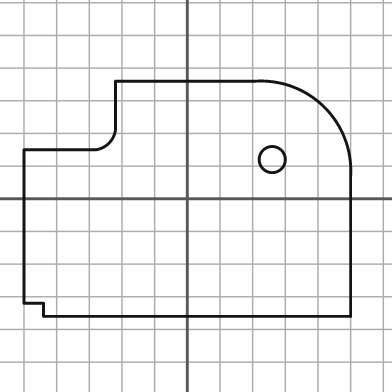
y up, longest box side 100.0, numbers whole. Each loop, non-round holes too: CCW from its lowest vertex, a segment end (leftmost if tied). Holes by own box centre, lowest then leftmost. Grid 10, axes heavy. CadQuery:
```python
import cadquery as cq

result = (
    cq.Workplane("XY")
    .moveTo(-44.0, -36.0)
    .lineTo(50.0, -36.0)
    .lineTo(50.0, 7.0)
    .threePointArc((42.0, 28.0), (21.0, 36.0))
    .lineTo(-22.0, 36.0)
    .lineTo(-22.0, 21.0)
    .threePointArc((-24.0, 17.0), (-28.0, 15.0))
    .lineTo(-50.0, 15.0)
    .lineTo(-50.0, -32.0)
    .lineTo(-44.0, -32.0)
    .close()
    .moveTo(26.0, 12.0)
    .circle(4.0)
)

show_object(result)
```